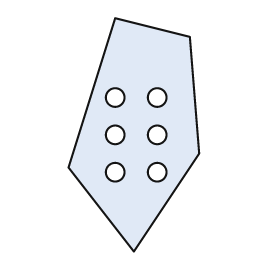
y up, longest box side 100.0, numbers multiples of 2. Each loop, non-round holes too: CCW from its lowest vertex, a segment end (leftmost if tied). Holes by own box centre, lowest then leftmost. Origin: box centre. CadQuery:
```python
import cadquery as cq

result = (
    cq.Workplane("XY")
    .moveTo(0.0, -50.0)
    .lineTo(28.0, -8.0)
    .lineTo(24.0, 42.0)
    .lineTo(-8.0, 50.0)
    .lineTo(-28.0, -14.0)
    .close()
    .moveTo(-8.0, -16.0)
    .circle(4.0)
    .moveTo(10.0, -16.0)
    .circle(4.0)
    .moveTo(-8.0, 0.0)
    .circle(4.0)
    .moveTo(10.0, 0.0)
    .circle(4.0)
    .moveTo(-8.0, 16.0)
    .circle(4.0)
    .moveTo(10.0, 16.0)
    .circle(4.0)
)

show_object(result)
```